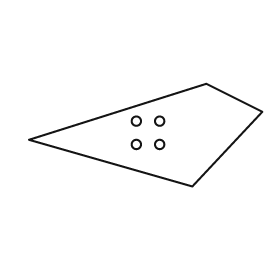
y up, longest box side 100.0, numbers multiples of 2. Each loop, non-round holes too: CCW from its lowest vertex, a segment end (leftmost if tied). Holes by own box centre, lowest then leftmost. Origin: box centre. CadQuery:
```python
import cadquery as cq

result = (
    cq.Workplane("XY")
    .moveTo(20.0, -22.0)
    .lineTo(50.0, 10.0)
    .lineTo(26.0, 22.0)
    .lineTo(-50.0, -2.0)
    .close()
    .moveTo(-4.0, -4.0)
    .circle(2.0)
    .moveTo(6.0, -4.0)
    .circle(2.0)
    .moveTo(-4.0, 6.0)
    .circle(2.0)
    .moveTo(6.0, 6.0)
    .circle(2.0)
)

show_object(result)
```